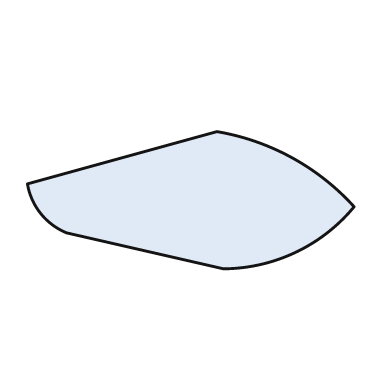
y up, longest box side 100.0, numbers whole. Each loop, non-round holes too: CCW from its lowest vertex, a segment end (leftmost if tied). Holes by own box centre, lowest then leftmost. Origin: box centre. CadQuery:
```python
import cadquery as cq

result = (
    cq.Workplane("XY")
    .moveTo(10.0, -21.0)
    .threePointArc((32.0, -16.0), (50.0, -2.0))
    .threePointArc((31.0, 13.0), (8.0, 21.0))
    .lineTo(-50.0, 5.0)
    .threePointArc((-46.0, -4.0), (-38.0, -10.0))
    .close()
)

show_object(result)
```